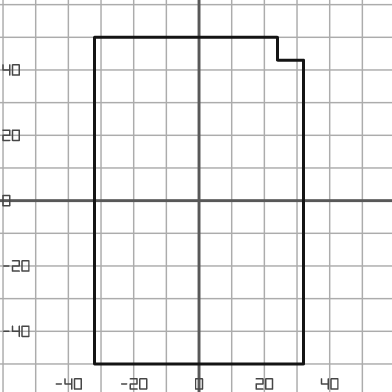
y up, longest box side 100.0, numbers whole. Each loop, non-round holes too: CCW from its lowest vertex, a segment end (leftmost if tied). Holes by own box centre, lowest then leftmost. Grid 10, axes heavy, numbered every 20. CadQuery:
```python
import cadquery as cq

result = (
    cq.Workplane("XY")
    .moveTo(-32.0, -50.0)
    .lineTo(32.0, -50.0)
    .lineTo(32.0, 43.0)
    .lineTo(24.0, 43.0)
    .lineTo(24.0, 50.0)
    .lineTo(-32.0, 50.0)
    .close()
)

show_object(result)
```